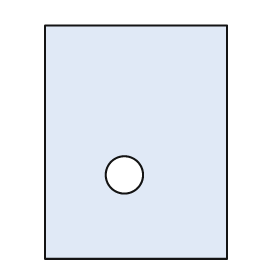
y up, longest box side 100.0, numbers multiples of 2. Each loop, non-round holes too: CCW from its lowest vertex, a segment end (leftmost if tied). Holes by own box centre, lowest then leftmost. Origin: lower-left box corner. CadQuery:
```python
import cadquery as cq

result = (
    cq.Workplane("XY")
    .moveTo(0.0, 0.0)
    .lineTo(78.0, 0.0)
    .lineTo(78.0, 100.0)
    .lineTo(0.0, 100.0)
    .close()
    .moveTo(34.0, 36.0)
    .circle(8.0)
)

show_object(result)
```